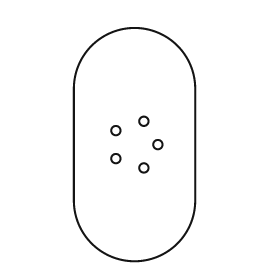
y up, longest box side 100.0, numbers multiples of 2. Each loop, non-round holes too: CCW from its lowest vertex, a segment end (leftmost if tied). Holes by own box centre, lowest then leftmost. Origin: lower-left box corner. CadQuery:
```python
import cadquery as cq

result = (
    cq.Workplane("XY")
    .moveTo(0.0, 26.0)
    .threePointArc((26.0, 0.0), (52.0, 26.0))
    .lineTo(52.0, 74.0)
    .threePointArc((26.0, 100.0), (0.0, 74.0))
    .close()
    .moveTo(30.0, 40.0)
    .circle(2.0)
    .moveTo(18.0, 44.0)
    .circle(2.0)
    .moveTo(36.0, 50.0)
    .circle(2.0)
    .moveTo(18.0, 56.0)
    .circle(2.0)
    .moveTo(30.0, 60.0)
    .circle(2.0)
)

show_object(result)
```